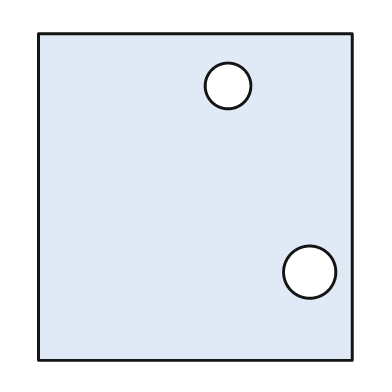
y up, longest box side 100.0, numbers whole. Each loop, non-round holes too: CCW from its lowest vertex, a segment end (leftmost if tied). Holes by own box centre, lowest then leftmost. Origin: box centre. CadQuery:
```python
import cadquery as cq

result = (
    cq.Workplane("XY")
    .moveTo(-48.0, -50.0)
    .lineTo(48.0, -50.0)
    .lineTo(48.0, 50.0)
    .lineTo(-48.0, 50.0)
    .close()
    .moveTo(35.0, -23.0)
    .circle(8.0)
    .moveTo(10.0, 34.0)
    .circle(7.0)
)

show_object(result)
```